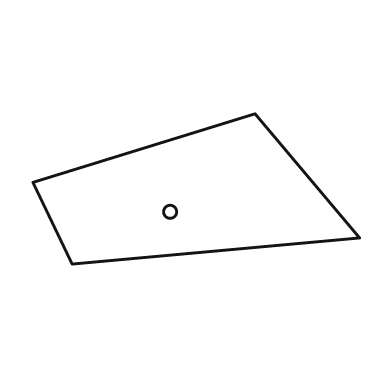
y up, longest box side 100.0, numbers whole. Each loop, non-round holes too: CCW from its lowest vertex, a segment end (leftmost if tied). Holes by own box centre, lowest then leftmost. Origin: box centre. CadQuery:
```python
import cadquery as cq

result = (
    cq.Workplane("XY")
    .moveTo(-38.0, -23.0)
    .lineTo(50.0, -15.0)
    .lineTo(18.0, 23.0)
    .lineTo(-50.0, 2.0)
    .close()
    .moveTo(-8.0, -7.0)
    .circle(2.0)
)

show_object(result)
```